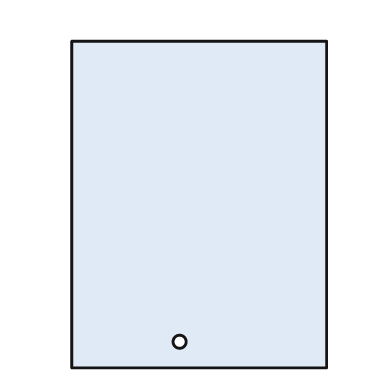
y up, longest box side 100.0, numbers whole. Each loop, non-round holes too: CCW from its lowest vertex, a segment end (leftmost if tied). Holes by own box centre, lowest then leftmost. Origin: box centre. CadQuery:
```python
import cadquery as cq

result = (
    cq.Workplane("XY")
    .moveTo(-39.0, -50.0)
    .lineTo(39.0, -50.0)
    .lineTo(39.0, 50.0)
    .lineTo(-39.0, 50.0)
    .close()
    .moveTo(-6.0, -42.0)
    .circle(2.0)
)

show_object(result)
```